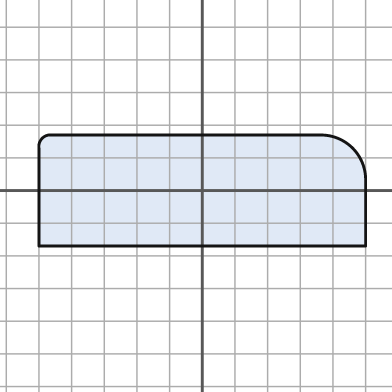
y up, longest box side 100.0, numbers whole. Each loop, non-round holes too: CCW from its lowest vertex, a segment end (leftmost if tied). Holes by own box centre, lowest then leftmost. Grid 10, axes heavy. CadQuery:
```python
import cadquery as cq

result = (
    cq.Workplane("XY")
    .moveTo(-50.0, -17.0)
    .lineTo(50.0, -17.0)
    .lineTo(50.0, 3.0)
    .threePointArc((46.0, 13.0), (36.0, 17.0))
    .lineTo(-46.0, 17.0)
    .threePointArc((-49.0, 16.0), (-50.0, 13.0))
    .close()
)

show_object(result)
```